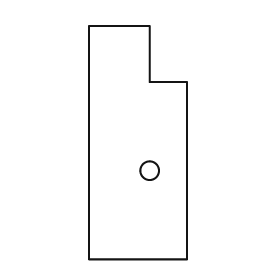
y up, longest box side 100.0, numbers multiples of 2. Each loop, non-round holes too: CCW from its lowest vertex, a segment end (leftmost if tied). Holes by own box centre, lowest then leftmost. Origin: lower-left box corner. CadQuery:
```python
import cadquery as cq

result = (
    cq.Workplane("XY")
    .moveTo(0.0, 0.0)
    .lineTo(42.0, 0.0)
    .lineTo(42.0, 76.0)
    .lineTo(26.0, 76.0)
    .lineTo(26.0, 100.0)
    .lineTo(0.0, 100.0)
    .close()
    .moveTo(26.0, 38.0)
    .circle(4.0)
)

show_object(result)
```